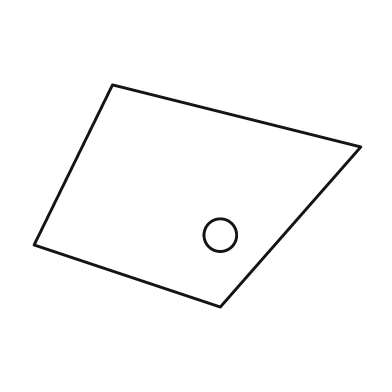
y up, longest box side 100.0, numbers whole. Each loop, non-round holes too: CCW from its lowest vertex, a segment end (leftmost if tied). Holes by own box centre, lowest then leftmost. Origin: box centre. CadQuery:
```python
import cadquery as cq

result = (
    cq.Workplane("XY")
    .moveTo(7.0, -34.0)
    .lineTo(50.0, 15.0)
    .lineTo(-26.0, 34.0)
    .lineTo(-50.0, -15.0)
    .close()
    .moveTo(7.0, -12.0)
    .circle(5.0)
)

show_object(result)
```